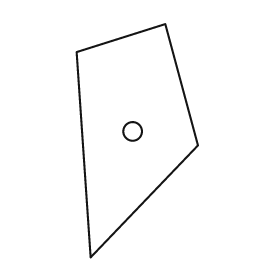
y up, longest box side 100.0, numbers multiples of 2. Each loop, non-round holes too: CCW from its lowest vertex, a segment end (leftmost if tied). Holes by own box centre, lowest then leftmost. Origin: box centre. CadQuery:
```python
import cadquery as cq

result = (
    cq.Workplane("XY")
    .moveTo(-20.0, -50.0)
    .lineTo(26.0, -2.0)
    .lineTo(12.0, 50.0)
    .lineTo(-26.0, 38.0)
    .close()
    .moveTo(-2.0, 4.0)
    .circle(4.0)
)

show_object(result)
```